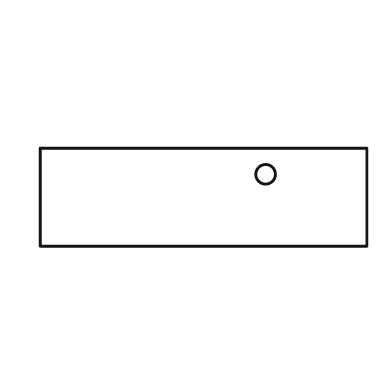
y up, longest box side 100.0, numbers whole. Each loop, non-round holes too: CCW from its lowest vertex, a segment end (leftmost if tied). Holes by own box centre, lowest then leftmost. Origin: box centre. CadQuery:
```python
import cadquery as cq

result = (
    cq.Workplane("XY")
    .moveTo(-50.0, -15.0)
    .lineTo(50.0, -15.0)
    .lineTo(50.0, 15.0)
    .lineTo(-50.0, 15.0)
    .close()
    .moveTo(19.0, 7.0)
    .circle(3.0)
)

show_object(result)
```